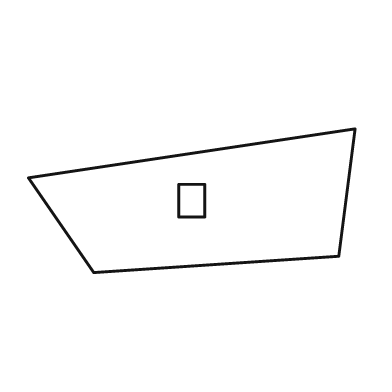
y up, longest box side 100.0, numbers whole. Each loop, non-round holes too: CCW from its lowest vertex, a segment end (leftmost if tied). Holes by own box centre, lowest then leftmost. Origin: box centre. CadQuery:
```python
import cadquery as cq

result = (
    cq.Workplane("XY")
    .moveTo(-30.0, -22.0)
    .lineTo(45.0, -17.0)
    .lineTo(50.0, 22.0)
    .lineTo(-50.0, 7.0)
    .close()
    .moveTo(-4.0, -5.0)
    .lineTo(4.0, -5.0)
    .lineTo(4.0, 5.0)
    .lineTo(-4.0, 5.0)
    .close()
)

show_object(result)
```